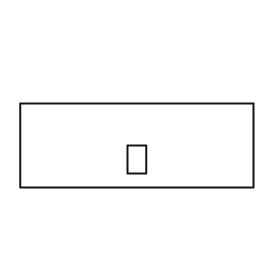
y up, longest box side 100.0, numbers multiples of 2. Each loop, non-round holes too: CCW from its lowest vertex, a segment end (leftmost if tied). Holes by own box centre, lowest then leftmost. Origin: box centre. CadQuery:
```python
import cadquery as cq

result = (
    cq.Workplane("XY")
    .moveTo(-50.0, -18.0)
    .lineTo(50.0, -18.0)
    .lineTo(50.0, 18.0)
    .lineTo(-50.0, 18.0)
    .close()
    .moveTo(-4.0, -12.0)
    .lineTo(4.0, -12.0)
    .lineTo(4.0, 0.0)
    .lineTo(-4.0, 0.0)
    .close()
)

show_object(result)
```